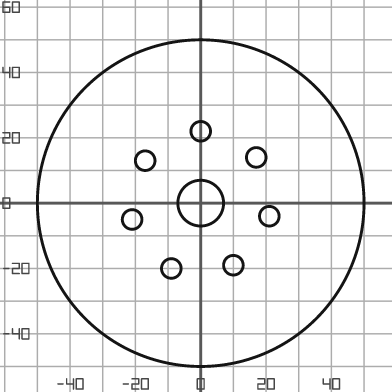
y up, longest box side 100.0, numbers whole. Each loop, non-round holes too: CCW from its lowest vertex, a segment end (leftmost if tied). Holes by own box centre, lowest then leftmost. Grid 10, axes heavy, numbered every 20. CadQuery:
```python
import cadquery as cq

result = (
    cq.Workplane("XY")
    .moveTo(0.0, 0.0)
    .circle(50.0)
    .moveTo(-9.0, -20.0)
    .circle(3.0)
    .moveTo(10.0, -19.0)
    .circle(3.0)
    .moveTo(-21.0, -5.0)
    .circle(3.0)
    .moveTo(21.0, -4.0)
    .circle(3.0)
    .moveTo(0.0, 0.0)
    .circle(7.0)
    .moveTo(-17.0, 13.0)
    .circle(3.0)
    .moveTo(17.0, 14.0)
    .circle(3.0)
    .moveTo(0.0, 22.0)
    .circle(3.0)
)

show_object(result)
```